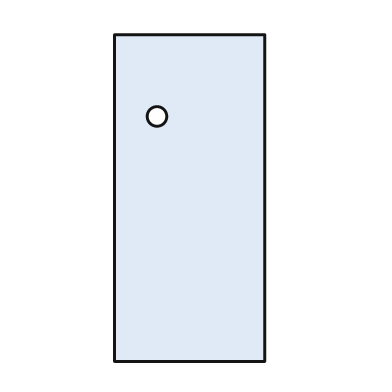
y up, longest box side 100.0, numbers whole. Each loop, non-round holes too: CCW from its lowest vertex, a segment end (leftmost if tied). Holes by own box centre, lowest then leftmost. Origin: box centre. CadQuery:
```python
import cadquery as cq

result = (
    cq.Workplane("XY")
    .moveTo(-23.0, -50.0)
    .lineTo(23.0, -50.0)
    .lineTo(23.0, 50.0)
    .lineTo(-23.0, 50.0)
    .close()
    .moveTo(-10.0, 25.0)
    .circle(3.0)
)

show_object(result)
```